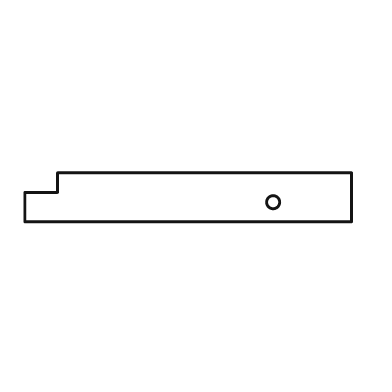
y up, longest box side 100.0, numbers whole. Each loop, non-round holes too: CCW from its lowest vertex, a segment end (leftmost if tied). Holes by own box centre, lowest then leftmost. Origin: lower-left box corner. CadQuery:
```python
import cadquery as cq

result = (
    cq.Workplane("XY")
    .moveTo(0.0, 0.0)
    .lineTo(100.0, 0.0)
    .lineTo(100.0, 15.0)
    .lineTo(10.0, 15.0)
    .lineTo(10.0, 9.0)
    .lineTo(0.0, 9.0)
    .close()
    .moveTo(76.0, 6.0)
    .circle(2.0)
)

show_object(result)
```